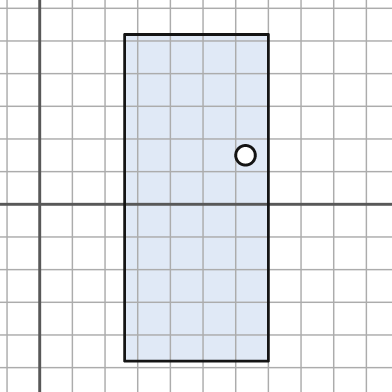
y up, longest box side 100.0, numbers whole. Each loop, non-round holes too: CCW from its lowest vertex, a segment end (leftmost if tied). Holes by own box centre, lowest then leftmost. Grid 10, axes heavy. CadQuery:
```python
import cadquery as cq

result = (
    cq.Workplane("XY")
    .moveTo(26.0, -48.0)
    .lineTo(70.0, -48.0)
    .lineTo(70.0, 52.0)
    .lineTo(26.0, 52.0)
    .close()
    .moveTo(63.0, 15.0)
    .circle(3.0)
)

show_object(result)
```